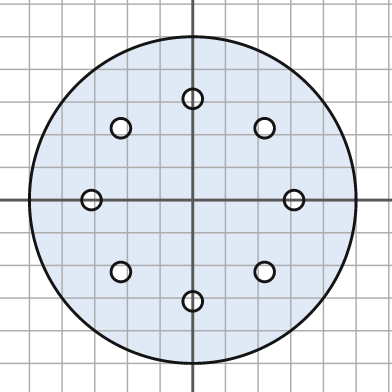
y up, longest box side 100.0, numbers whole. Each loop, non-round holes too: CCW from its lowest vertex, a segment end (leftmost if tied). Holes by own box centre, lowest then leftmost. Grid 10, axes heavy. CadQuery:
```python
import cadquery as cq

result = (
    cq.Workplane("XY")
    .moveTo(0.0, 0.0)
    .circle(50.0)
    .moveTo(0.0, -31.0)
    .circle(3.0)
    .moveTo(-22.0, -22.0)
    .circle(3.0)
    .moveTo(22.0, -22.0)
    .circle(3.0)
    .moveTo(-31.0, 0.0)
    .circle(3.0)
    .moveTo(31.0, 0.0)
    .circle(3.0)
    .moveTo(-22.0, 22.0)
    .circle(3.0)
    .moveTo(22.0, 22.0)
    .circle(3.0)
    .moveTo(0.0, 31.0)
    .circle(3.0)
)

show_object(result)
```